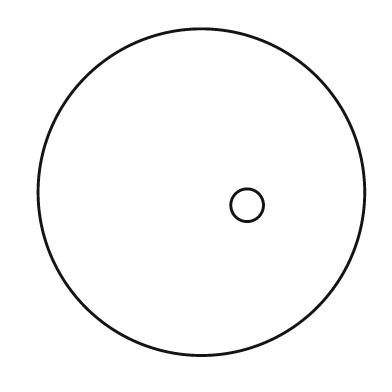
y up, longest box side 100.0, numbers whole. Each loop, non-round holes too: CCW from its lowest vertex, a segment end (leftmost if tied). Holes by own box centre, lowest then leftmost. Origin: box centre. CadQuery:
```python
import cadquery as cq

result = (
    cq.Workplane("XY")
    .moveTo(0.0, 0.0)
    .circle(50.0)
    .moveTo(14.0, -4.0)
    .circle(5.0)
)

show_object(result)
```